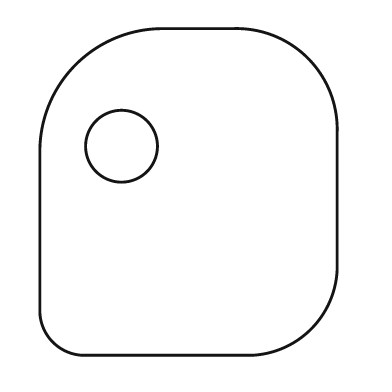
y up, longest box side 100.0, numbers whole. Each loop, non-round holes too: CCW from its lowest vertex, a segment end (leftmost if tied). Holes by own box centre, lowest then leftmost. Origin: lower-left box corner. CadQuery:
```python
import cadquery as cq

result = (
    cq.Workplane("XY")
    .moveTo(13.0, 0.0)
    .lineTo(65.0, 0.0)
    .threePointArc((83.0, 8.0), (91.0, 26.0))
    .lineTo(91.0, 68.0)
    .threePointArc((82.0, 91.0), (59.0, 100.0))
    .lineTo(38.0, 100.0)
    .threePointArc((11.0, 89.0), (0.0, 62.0))
    .lineTo(0.0, 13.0)
    .threePointArc((4.0, 4.0), (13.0, 0.0))
    .close()
    .moveTo(25.0, 64.0)
    .circle(11.0)
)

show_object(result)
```